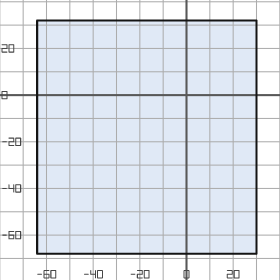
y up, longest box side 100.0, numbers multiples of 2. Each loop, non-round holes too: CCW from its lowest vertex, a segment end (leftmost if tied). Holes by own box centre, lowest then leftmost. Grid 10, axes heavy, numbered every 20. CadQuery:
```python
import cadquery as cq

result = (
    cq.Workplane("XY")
    .moveTo(-64.0, -68.0)
    .lineTo(30.0, -68.0)
    .lineTo(30.0, 32.0)
    .lineTo(-64.0, 32.0)
    .close()
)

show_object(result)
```